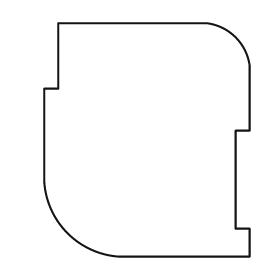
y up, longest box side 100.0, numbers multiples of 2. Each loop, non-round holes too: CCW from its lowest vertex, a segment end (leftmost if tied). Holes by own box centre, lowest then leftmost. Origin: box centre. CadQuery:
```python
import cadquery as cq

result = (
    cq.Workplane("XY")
    .moveTo(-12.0, -50.0)
    .lineTo(44.0, -50.0)
    .lineTo(44.0, -38.0)
    .lineTo(38.0, -38.0)
    .lineTo(38.0, 4.0)
    .lineTo(44.0, 4.0)
    .lineTo(44.0, 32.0)
    .threePointArc((38.0, 44.0), (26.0, 50.0))
    .lineTo(-38.0, 50.0)
    .lineTo(-38.0, 22.0)
    .lineTo(-44.0, 22.0)
    .lineTo(-44.0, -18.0)
    .threePointArc((-34.0, -40.0), (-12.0, -50.0))
    .close()
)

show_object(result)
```